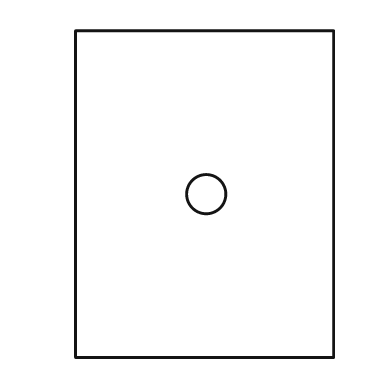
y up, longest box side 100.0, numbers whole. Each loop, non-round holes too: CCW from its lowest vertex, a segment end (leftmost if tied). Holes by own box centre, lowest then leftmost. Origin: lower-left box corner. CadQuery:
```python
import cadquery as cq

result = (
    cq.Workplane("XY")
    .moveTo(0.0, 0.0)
    .lineTo(79.0, 0.0)
    .lineTo(79.0, 100.0)
    .lineTo(0.0, 100.0)
    .close()
    .moveTo(40.0, 50.0)
    .circle(6.0)
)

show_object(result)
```